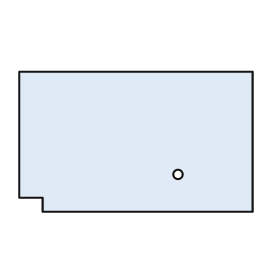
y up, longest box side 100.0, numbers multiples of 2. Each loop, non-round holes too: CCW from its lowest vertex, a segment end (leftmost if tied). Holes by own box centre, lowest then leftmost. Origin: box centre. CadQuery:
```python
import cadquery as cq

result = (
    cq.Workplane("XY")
    .moveTo(-40.0, -30.0)
    .lineTo(50.0, -30.0)
    .lineTo(50.0, 30.0)
    .lineTo(-50.0, 30.0)
    .lineTo(-50.0, -24.0)
    .lineTo(-40.0, -24.0)
    .close()
    .moveTo(18.0, -14.0)
    .circle(2.0)
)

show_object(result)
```